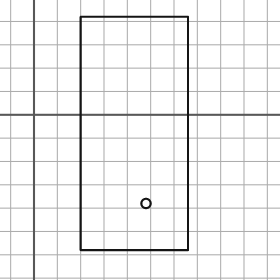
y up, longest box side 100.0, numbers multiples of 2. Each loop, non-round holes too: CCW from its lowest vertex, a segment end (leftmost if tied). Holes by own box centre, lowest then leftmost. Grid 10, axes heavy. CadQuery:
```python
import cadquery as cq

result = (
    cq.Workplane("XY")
    .moveTo(20.0, -58.0)
    .lineTo(66.0, -58.0)
    .lineTo(66.0, 42.0)
    .lineTo(20.0, 42.0)
    .close()
    .moveTo(48.0, -38.0)
    .circle(2.0)
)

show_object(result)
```